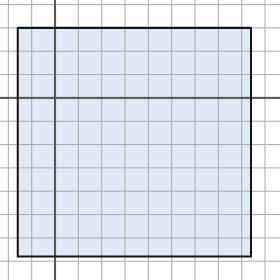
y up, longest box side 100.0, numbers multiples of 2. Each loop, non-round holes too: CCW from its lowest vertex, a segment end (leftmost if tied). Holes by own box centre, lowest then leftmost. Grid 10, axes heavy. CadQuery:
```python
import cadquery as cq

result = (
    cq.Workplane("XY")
    .moveTo(-16.0, -68.0)
    .lineTo(84.0, -68.0)
    .lineTo(84.0, 30.0)
    .lineTo(-16.0, 30.0)
    .close()
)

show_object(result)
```